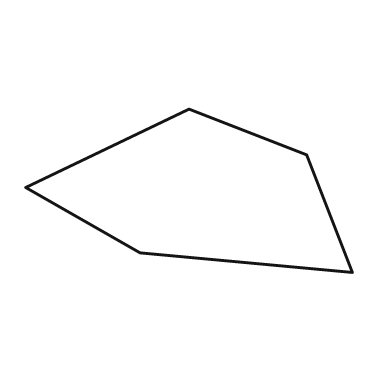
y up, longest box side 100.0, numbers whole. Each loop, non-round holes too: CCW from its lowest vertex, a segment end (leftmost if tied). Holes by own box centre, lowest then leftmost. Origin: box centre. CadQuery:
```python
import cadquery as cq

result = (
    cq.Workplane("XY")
    .moveTo(50.0, -25.0)
    .lineTo(36.0, 11.0)
    .lineTo(0.0, 25.0)
    .lineTo(-50.0, 1.0)
    .lineTo(-15.0, -19.0)
    .close()
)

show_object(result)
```